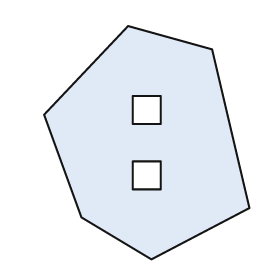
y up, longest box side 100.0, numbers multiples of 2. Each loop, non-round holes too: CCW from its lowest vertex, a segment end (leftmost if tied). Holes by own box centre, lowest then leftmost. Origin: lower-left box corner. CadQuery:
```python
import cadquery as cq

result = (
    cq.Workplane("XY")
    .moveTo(46.0, 0.0)
    .lineTo(88.0, 22.0)
    .lineTo(72.0, 90.0)
    .lineTo(36.0, 100.0)
    .lineTo(0.0, 62.0)
    .lineTo(16.0, 18.0)
    .close()
    .moveTo(38.0, 30.0)
    .lineTo(50.0, 30.0)
    .lineTo(50.0, 42.0)
    .lineTo(38.0, 42.0)
    .close()
    .moveTo(38.0, 58.0)
    .lineTo(50.0, 58.0)
    .lineTo(50.0, 70.0)
    .lineTo(38.0, 70.0)
    .close()
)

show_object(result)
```